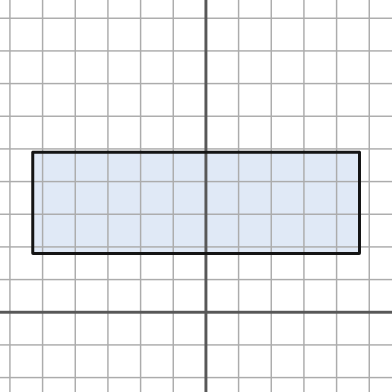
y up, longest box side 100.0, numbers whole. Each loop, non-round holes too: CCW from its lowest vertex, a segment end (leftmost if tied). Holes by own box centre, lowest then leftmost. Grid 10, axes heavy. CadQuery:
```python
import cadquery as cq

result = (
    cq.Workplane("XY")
    .moveTo(-53.0, 18.0)
    .lineTo(47.0, 18.0)
    .lineTo(47.0, 49.0)
    .lineTo(-53.0, 49.0)
    .close()
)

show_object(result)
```